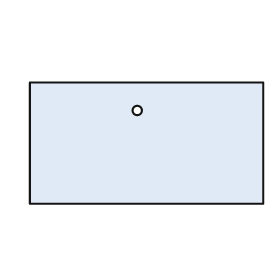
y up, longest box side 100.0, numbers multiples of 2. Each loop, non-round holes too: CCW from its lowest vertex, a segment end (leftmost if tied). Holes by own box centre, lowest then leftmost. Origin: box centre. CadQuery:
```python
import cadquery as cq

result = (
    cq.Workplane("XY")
    .moveTo(-50.0, -26.0)
    .lineTo(50.0, -26.0)
    .lineTo(50.0, 26.0)
    .lineTo(-50.0, 26.0)
    .close()
    .moveTo(-4.0, 14.0)
    .circle(2.0)
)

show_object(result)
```